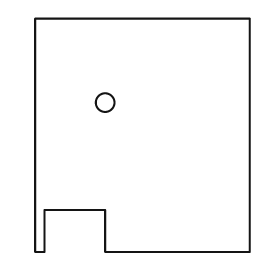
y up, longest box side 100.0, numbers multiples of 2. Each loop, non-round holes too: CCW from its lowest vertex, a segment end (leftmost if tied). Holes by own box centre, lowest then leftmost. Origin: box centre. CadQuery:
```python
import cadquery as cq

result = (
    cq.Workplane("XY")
    .moveTo(-46.0, -50.0)
    .lineTo(-42.0, -50.0)
    .lineTo(-42.0, -32.0)
    .lineTo(-16.0, -32.0)
    .lineTo(-16.0, -50.0)
    .lineTo(46.0, -50.0)
    .lineTo(46.0, 50.0)
    .lineTo(-46.0, 50.0)
    .close()
    .moveTo(-16.0, 14.0)
    .circle(4.0)
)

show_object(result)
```